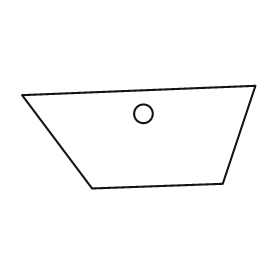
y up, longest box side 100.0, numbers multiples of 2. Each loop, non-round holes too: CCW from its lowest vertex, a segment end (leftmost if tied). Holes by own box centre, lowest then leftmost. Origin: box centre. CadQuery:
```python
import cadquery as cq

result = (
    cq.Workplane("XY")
    .moveTo(-20.0, -22.0)
    .lineTo(36.0, -20.0)
    .lineTo(50.0, 22.0)
    .lineTo(-50.0, 18.0)
    .close()
    .moveTo(2.0, 10.0)
    .circle(4.0)
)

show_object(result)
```